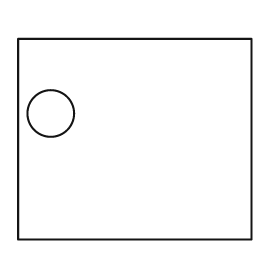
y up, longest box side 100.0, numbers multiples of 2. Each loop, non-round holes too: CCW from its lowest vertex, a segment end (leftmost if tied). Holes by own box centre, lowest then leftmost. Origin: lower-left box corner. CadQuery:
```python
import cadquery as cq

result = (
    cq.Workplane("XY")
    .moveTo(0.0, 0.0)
    .lineTo(100.0, 0.0)
    .lineTo(100.0, 86.0)
    .lineTo(0.0, 86.0)
    .close()
    .moveTo(14.0, 54.0)
    .circle(10.0)
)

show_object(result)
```